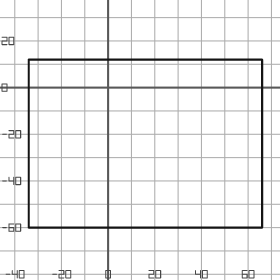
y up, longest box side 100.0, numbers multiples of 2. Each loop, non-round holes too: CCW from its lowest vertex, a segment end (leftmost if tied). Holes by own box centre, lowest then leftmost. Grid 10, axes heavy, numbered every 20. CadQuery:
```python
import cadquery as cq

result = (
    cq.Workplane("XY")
    .moveTo(-34.0, -60.0)
    .lineTo(66.0, -60.0)
    .lineTo(66.0, 12.0)
    .lineTo(-34.0, 12.0)
    .close()
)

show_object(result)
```